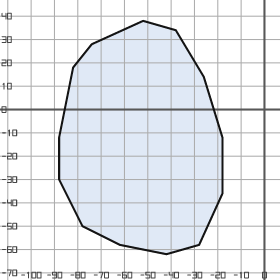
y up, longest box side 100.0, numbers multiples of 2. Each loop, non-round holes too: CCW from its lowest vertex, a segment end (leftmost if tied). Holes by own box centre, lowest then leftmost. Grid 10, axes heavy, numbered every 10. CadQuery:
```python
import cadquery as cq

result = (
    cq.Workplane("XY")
    .moveTo(-42.0, -62.0)
    .lineTo(-28.0, -58.0)
    .lineTo(-18.0, -36.0)
    .lineTo(-18.0, -12.0)
    .lineTo(-26.0, 14.0)
    .lineTo(-38.0, 34.0)
    .lineTo(-52.0, 38.0)
    .lineTo(-74.0, 28.0)
    .lineTo(-82.0, 18.0)
    .lineTo(-88.0, -12.0)
    .lineTo(-88.0, -30.0)
    .lineTo(-78.0, -50.0)
    .lineTo(-62.0, -58.0)
    .close()
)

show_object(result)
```